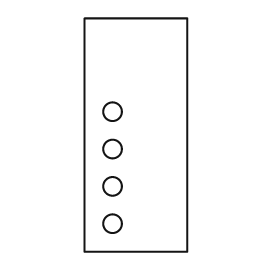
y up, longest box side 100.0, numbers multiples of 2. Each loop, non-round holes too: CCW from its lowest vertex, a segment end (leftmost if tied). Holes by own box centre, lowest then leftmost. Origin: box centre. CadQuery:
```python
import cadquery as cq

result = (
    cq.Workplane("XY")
    .moveTo(-22.0, -50.0)
    .lineTo(22.0, -50.0)
    .lineTo(22.0, 50.0)
    .lineTo(-22.0, 50.0)
    .close()
    .moveTo(-10.0, -38.0)
    .circle(4.0)
    .moveTo(-10.0, -22.0)
    .circle(4.0)
    .moveTo(-10.0, -6.0)
    .circle(4.0)
    .moveTo(-10.0, 10.0)
    .circle(4.0)
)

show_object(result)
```